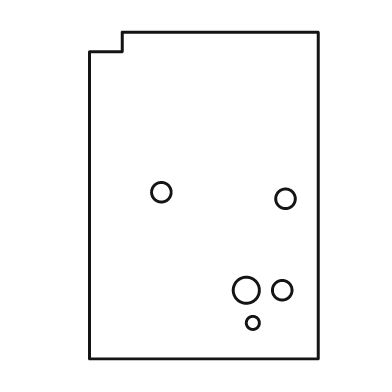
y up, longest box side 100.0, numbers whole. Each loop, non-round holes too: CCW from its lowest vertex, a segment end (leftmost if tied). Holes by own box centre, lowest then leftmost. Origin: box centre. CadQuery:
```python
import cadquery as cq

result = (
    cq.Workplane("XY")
    .moveTo(-35.0, -50.0)
    .lineTo(35.0, -50.0)
    .lineTo(35.0, 50.0)
    .lineTo(-25.0, 50.0)
    .lineTo(-25.0, 44.0)
    .lineTo(-35.0, 44.0)
    .close()
    .moveTo(15.0, -39.0)
    .circle(2.0)
    .moveTo(13.0, -29.0)
    .circle(4.0)
    .moveTo(24.0, -29.0)
    .circle(3.0)
    .moveTo(25.0, -1.0)
    .circle(3.0)
    .moveTo(-13.0, 1.0)
    .circle(3.0)
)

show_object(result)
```